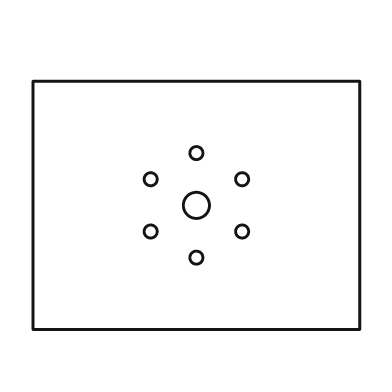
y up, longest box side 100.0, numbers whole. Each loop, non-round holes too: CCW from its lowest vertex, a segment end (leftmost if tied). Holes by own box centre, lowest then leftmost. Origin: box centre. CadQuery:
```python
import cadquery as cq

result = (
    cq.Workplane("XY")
    .moveTo(-50.0, -38.0)
    .lineTo(50.0, -38.0)
    .lineTo(50.0, 38.0)
    .lineTo(-50.0, 38.0)
    .close()
    .moveTo(0.0, -16.0)
    .circle(2.0)
    .moveTo(-14.0, -8.0)
    .circle(2.0)
    .moveTo(14.0, -8.0)
    .circle(2.0)
    .moveTo(0.0, 0.0)
    .circle(4.0)
    .moveTo(-14.0, 8.0)
    .circle(2.0)
    .moveTo(14.0, 8.0)
    .circle(2.0)
    .moveTo(0.0, 16.0)
    .circle(2.0)
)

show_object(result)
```